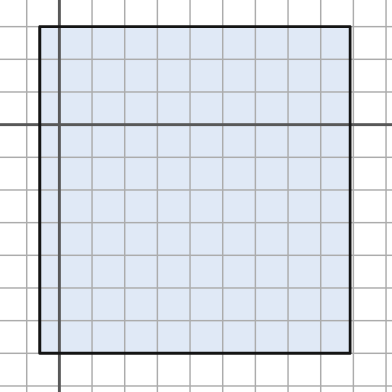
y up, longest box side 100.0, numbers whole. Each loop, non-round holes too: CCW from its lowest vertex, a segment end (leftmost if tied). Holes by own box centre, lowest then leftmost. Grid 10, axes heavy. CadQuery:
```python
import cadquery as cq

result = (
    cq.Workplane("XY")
    .moveTo(-6.0, -70.0)
    .lineTo(89.0, -70.0)
    .lineTo(89.0, 30.0)
    .lineTo(-6.0, 30.0)
    .close()
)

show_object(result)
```